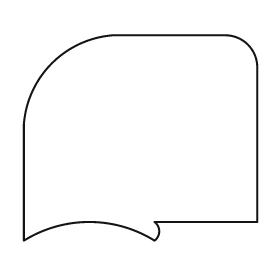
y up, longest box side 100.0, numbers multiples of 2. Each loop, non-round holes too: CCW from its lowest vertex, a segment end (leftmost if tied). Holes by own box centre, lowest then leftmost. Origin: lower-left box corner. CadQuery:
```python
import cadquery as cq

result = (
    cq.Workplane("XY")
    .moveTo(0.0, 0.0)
    .threePointArc((28.0, 8.0), (56.0, 0.0))
    .threePointArc((58.0, 4.0), (56.0, 8.0))
    .lineTo(100.0, 8.0)
    .lineTo(100.0, 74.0)
    .threePointArc((96.0, 84.0), (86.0, 88.0))
    .lineTo(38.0, 88.0)
    .threePointArc((12.0, 76.0), (0.0, 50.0))
    .close()
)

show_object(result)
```